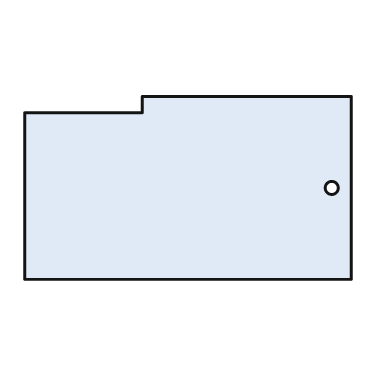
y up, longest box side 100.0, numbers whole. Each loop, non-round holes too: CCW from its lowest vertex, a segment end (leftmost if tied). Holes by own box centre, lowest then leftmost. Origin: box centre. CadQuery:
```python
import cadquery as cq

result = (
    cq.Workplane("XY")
    .moveTo(-50.0, -28.0)
    .lineTo(50.0, -28.0)
    .lineTo(50.0, 28.0)
    .lineTo(-14.0, 28.0)
    .lineTo(-14.0, 23.0)
    .lineTo(-50.0, 23.0)
    .close()
    .moveTo(44.0, 0.0)
    .circle(2.0)
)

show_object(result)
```